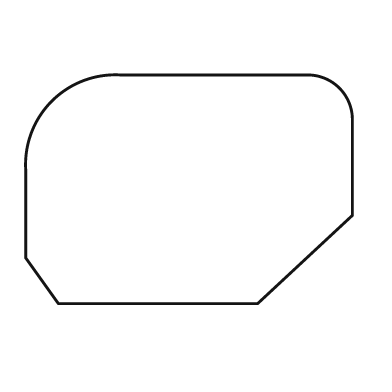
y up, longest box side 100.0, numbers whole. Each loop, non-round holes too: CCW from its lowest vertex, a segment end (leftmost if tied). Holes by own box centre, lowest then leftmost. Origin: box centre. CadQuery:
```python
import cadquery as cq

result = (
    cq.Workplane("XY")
    .moveTo(-40.0, -35.0)
    .lineTo(21.0, -35.0)
    .lineTo(50.0, -8.0)
    .lineTo(50.0, 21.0)
    .threePointArc((46.0, 31.0), (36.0, 35.0))
    .lineTo(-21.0, 35.0)
    .threePointArc((-42.0, 27.0), (-50.0, 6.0))
    .lineTo(-50.0, -21.0)
    .close()
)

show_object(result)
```